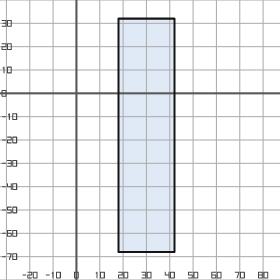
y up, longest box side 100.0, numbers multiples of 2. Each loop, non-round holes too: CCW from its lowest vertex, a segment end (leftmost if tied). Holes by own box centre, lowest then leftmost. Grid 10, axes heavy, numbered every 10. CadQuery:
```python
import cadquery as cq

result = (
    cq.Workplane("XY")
    .moveTo(18.0, -68.0)
    .lineTo(42.0, -68.0)
    .lineTo(42.0, 32.0)
    .lineTo(18.0, 32.0)
    .close()
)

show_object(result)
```